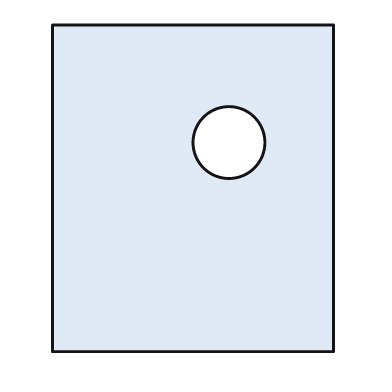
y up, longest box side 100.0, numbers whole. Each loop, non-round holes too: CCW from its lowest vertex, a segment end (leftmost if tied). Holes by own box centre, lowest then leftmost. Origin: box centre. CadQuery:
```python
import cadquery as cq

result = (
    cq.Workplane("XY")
    .moveTo(-43.0, -50.0)
    .lineTo(43.0, -50.0)
    .lineTo(43.0, 50.0)
    .lineTo(-43.0, 50.0)
    .close()
    .moveTo(11.0, 14.0)
    .circle(11.0)
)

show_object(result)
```